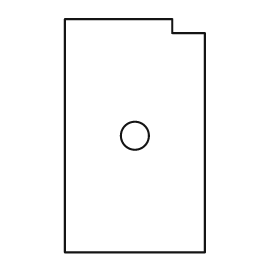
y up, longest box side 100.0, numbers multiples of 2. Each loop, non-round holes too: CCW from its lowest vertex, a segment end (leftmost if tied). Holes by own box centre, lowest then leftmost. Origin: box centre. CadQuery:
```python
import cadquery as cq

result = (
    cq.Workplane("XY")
    .moveTo(-30.0, -50.0)
    .lineTo(30.0, -50.0)
    .lineTo(30.0, 44.0)
    .lineTo(16.0, 44.0)
    .lineTo(16.0, 50.0)
    .lineTo(-30.0, 50.0)
    .close()
    .moveTo(0.0, 0.0)
    .circle(6.0)
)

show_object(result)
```